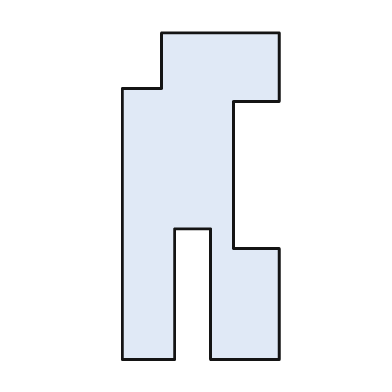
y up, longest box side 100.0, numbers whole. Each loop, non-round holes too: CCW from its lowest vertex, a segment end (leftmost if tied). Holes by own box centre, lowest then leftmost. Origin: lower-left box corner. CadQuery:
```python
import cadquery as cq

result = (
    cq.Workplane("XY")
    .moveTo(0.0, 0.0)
    .lineTo(16.0, 0.0)
    .lineTo(16.0, 40.0)
    .lineTo(27.0, 40.0)
    .lineTo(27.0, 0.0)
    .lineTo(48.0, 0.0)
    .lineTo(48.0, 34.0)
    .lineTo(34.0, 34.0)
    .lineTo(34.0, 79.0)
    .lineTo(48.0, 79.0)
    .lineTo(48.0, 100.0)
    .lineTo(12.0, 100.0)
    .lineTo(12.0, 83.0)
    .lineTo(0.0, 83.0)
    .close()
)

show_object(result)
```